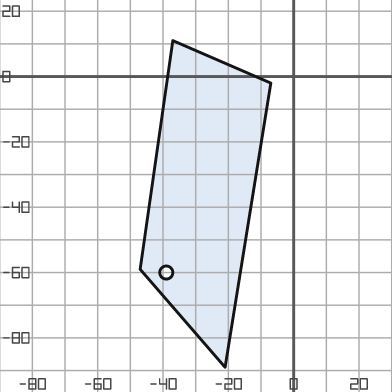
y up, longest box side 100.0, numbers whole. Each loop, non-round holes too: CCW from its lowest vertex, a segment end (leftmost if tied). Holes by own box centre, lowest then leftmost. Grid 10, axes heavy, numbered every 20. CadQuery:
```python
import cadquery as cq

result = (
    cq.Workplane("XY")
    .moveTo(-21.0, -89.0)
    .lineTo(-7.0, -2.0)
    .lineTo(-37.0, 11.0)
    .lineTo(-47.0, -59.0)
    .close()
    .moveTo(-39.0, -60.0)
    .circle(2.0)
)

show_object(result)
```